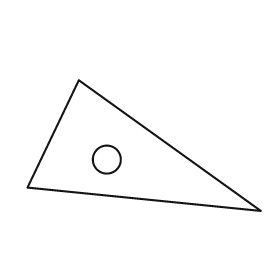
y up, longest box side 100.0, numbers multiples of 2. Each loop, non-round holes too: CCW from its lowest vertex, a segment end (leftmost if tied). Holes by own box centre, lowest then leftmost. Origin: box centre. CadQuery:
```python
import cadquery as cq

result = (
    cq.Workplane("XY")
    .moveTo(50.0, -28.0)
    .lineTo(-28.0, 28.0)
    .lineTo(-50.0, -18.0)
    .close()
    .moveTo(-16.0, -6.0)
    .circle(6.0)
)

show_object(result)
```